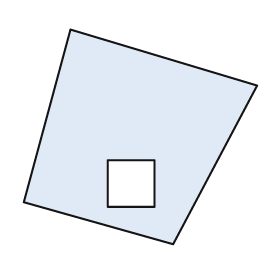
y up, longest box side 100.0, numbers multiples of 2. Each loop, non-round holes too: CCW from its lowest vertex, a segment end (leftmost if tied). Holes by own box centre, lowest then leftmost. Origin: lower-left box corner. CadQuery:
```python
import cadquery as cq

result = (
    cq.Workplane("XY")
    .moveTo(64.0, 0.0)
    .lineTo(100.0, 68.0)
    .lineTo(20.0, 92.0)
    .lineTo(0.0, 18.0)
    .close()
    .moveTo(36.0, 16.0)
    .lineTo(56.0, 16.0)
    .lineTo(56.0, 36.0)
    .lineTo(36.0, 36.0)
    .close()
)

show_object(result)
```